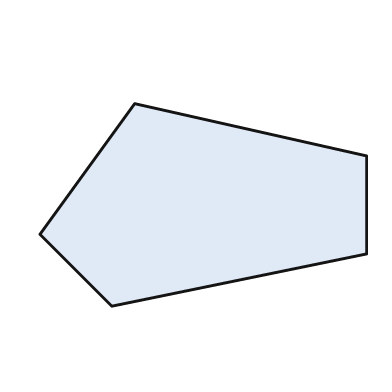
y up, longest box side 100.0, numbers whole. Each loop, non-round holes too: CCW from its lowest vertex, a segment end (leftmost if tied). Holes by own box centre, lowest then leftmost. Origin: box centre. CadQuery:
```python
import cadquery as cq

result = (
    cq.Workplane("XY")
    .moveTo(-28.0, -31.0)
    .lineTo(50.0, -15.0)
    .lineTo(50.0, 15.0)
    .lineTo(-21.0, 31.0)
    .lineTo(-50.0, -9.0)
    .close()
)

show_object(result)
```